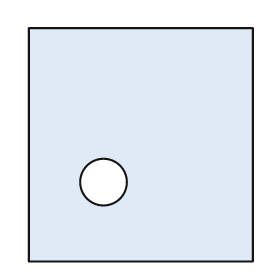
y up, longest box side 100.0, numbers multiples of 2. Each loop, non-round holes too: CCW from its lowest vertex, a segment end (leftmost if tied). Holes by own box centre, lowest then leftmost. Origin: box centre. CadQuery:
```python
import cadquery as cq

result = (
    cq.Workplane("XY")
    .moveTo(-48.0, -50.0)
    .lineTo(48.0, -50.0)
    .lineTo(48.0, 50.0)
    .lineTo(-48.0, 50.0)
    .close()
    .moveTo(-16.0, -16.0)
    .circle(10.0)
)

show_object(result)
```